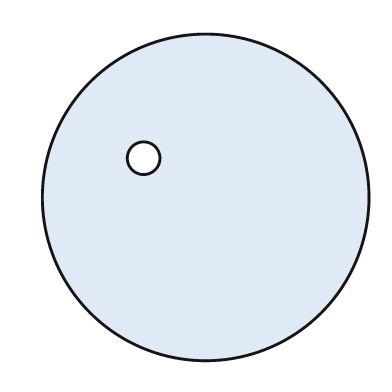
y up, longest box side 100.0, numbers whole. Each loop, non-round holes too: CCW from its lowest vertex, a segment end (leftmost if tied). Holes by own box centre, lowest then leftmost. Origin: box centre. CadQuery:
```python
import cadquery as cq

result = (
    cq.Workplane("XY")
    .moveTo(0.0, 0.0)
    .circle(50.0)
    .moveTo(-19.0, 12.0)
    .circle(5.0)
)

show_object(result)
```